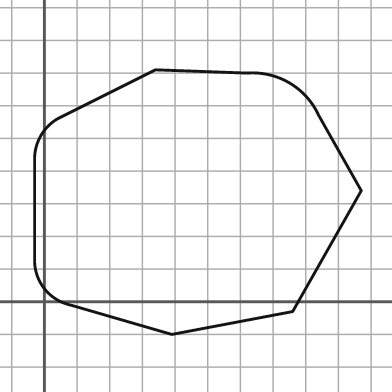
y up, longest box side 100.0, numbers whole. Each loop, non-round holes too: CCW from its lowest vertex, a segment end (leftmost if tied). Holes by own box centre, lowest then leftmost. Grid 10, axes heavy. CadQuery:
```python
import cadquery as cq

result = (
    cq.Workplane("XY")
    .moveTo(39.0, -10.0)
    .lineTo(76.0, -3.0)
    .lineTo(97.0, 34.0)
    .lineTo(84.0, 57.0)
    .threePointArc((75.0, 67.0), (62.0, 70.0))
    .lineTo(34.0, 71.0)
    .lineTo(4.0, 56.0)
    .threePointArc((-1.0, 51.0), (-3.0, 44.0))
    .lineTo(-3.0, 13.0)
    .threePointArc((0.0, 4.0), (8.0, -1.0))
    .close()
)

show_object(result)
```